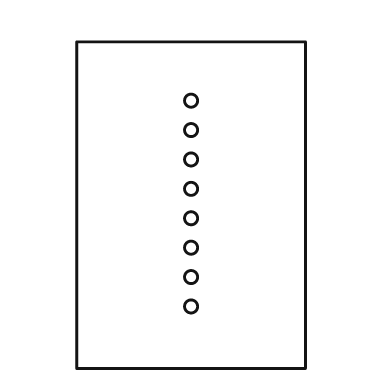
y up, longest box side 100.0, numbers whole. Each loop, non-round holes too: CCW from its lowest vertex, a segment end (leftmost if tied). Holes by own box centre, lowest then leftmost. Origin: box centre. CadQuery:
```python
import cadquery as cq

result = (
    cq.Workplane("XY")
    .moveTo(-35.0, -50.0)
    .lineTo(35.0, -50.0)
    .lineTo(35.0, 50.0)
    .lineTo(-35.0, 50.0)
    .close()
    .moveTo(0.0, -31.0)
    .circle(2.0)
    .moveTo(0.0, -22.0)
    .circle(2.0)
    .moveTo(0.0, -13.0)
    .circle(2.0)
    .moveTo(0.0, -4.0)
    .circle(2.0)
    .moveTo(0.0, 5.0)
    .circle(2.0)
    .moveTo(0.0, 14.0)
    .circle(2.0)
    .moveTo(0.0, 23.0)
    .circle(2.0)
    .moveTo(0.0, 32.0)
    .circle(2.0)
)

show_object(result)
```